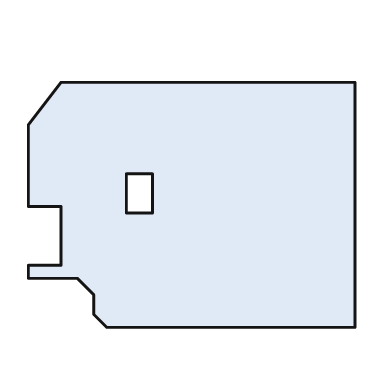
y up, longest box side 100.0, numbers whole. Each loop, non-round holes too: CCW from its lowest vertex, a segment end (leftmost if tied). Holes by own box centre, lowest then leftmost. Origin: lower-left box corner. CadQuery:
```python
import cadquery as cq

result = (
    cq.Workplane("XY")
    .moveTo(24.0, 0.0)
    .lineTo(100.0, 0.0)
    .lineTo(100.0, 75.0)
    .lineTo(10.0, 75.0)
    .lineTo(0.0, 62.0)
    .lineTo(0.0, 37.0)
    .lineTo(10.0, 37.0)
    .lineTo(10.0, 19.0)
    .lineTo(0.0, 19.0)
    .lineTo(0.0, 15.0)
    .lineTo(15.0, 15.0)
    .lineTo(20.0, 10.0)
    .lineTo(20.0, 4.0)
    .close()
    .moveTo(30.0, 35.0)
    .lineTo(38.0, 35.0)
    .lineTo(38.0, 47.0)
    .lineTo(30.0, 47.0)
    .close()
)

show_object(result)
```